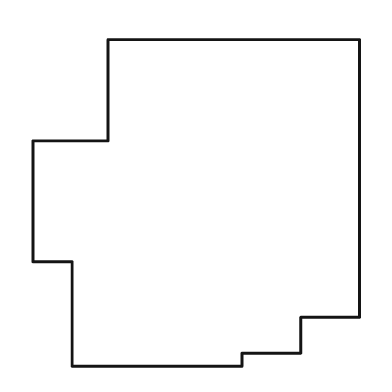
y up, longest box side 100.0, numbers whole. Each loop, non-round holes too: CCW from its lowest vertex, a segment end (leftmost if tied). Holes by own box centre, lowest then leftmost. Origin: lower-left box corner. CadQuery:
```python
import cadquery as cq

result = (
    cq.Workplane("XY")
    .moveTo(12.0, 0.0)
    .lineTo(64.0, 0.0)
    .lineTo(64.0, 4.0)
    .lineTo(82.0, 4.0)
    .lineTo(82.0, 15.0)
    .lineTo(100.0, 15.0)
    .lineTo(100.0, 100.0)
    .lineTo(23.0, 100.0)
    .lineTo(23.0, 69.0)
    .lineTo(0.0, 69.0)
    .lineTo(0.0, 32.0)
    .lineTo(12.0, 32.0)
    .close()
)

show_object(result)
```